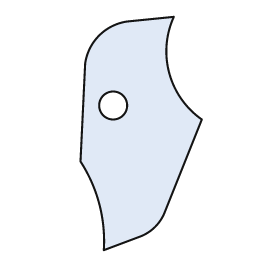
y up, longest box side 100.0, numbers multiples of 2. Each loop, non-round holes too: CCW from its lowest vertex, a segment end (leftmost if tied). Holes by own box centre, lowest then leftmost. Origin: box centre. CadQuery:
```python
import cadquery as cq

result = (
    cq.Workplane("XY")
    .moveTo(-16.0, -50.0)
    .lineTo(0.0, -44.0)
    .threePointArc((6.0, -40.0), (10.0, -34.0))
    .lineTo(26.0, 6.0)
    .threePointArc((12.0, 26.0), (14.0, 50.0))
    .lineTo(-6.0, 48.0)
    .threePointArc((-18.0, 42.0), (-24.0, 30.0))
    .lineTo(-26.0, -12.0)
    .threePointArc((-18.0, -30.0), (-16.0, -50.0))
    .close()
    .moveTo(-12.0, 12.0)
    .circle(6.0)
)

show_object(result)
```